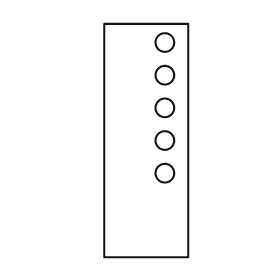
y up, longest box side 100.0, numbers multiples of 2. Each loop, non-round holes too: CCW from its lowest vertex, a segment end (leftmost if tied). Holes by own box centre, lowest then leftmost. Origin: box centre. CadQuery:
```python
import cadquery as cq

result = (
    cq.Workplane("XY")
    .moveTo(-18.0, -50.0)
    .lineTo(18.0, -50.0)
    .lineTo(18.0, 50.0)
    .lineTo(-18.0, 50.0)
    .close()
    .moveTo(8.0, -14.0)
    .circle(4.0)
    .moveTo(8.0, 0.0)
    .circle(4.0)
    .moveTo(8.0, 14.0)
    .circle(4.0)
    .moveTo(8.0, 28.0)
    .circle(4.0)
    .moveTo(8.0, 42.0)
    .circle(4.0)
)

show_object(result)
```